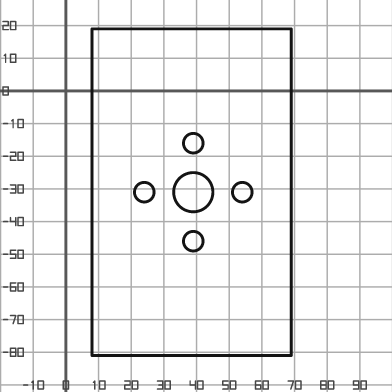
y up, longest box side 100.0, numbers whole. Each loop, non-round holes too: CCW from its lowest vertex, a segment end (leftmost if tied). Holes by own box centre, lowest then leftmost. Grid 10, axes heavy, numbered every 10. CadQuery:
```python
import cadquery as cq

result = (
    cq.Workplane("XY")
    .moveTo(8.0, -81.0)
    .lineTo(69.0, -81.0)
    .lineTo(69.0, 19.0)
    .lineTo(8.0, 19.0)
    .close()
    .moveTo(39.0, -46.0)
    .circle(3.0)
    .moveTo(24.0, -31.0)
    .circle(3.0)
    .moveTo(39.0, -31.0)
    .circle(6.0)
    .moveTo(54.0, -31.0)
    .circle(3.0)
    .moveTo(39.0, -16.0)
    .circle(3.0)
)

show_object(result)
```